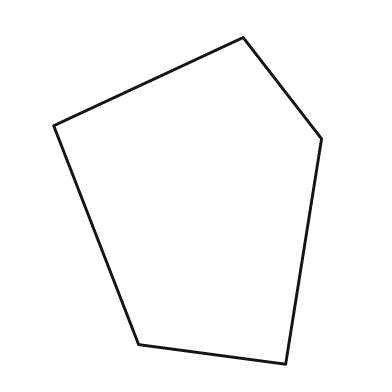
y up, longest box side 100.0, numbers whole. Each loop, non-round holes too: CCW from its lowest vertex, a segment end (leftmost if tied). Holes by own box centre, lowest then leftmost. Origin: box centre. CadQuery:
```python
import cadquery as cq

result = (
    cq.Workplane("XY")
    .moveTo(30.0, -50.0)
    .lineTo(41.0, 19.0)
    .lineTo(17.0, 50.0)
    .lineTo(-41.0, 23.0)
    .lineTo(-15.0, -44.0)
    .close()
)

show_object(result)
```